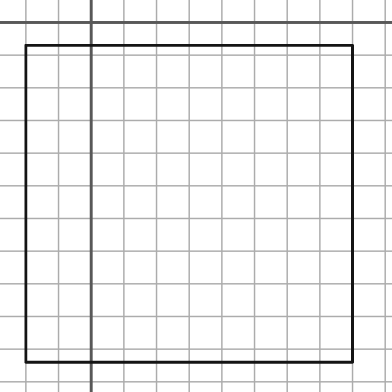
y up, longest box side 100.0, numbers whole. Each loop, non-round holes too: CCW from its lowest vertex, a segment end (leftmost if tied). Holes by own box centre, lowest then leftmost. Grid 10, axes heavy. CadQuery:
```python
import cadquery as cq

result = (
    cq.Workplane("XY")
    .moveTo(-20.0, -104.0)
    .lineTo(80.0, -104.0)
    .lineTo(80.0, -7.0)
    .lineTo(-20.0, -7.0)
    .close()
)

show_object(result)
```